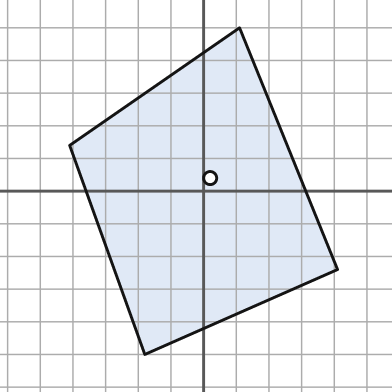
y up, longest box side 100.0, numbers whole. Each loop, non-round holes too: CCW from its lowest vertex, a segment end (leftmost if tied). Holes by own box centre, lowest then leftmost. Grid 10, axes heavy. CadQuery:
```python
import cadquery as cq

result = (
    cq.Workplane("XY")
    .moveTo(-18.0, -50.0)
    .lineTo(41.0, -24.0)
    .lineTo(11.0, 50.0)
    .lineTo(-41.0, 14.0)
    .close()
    .moveTo(2.0, 4.0)
    .circle(2.0)
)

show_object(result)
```